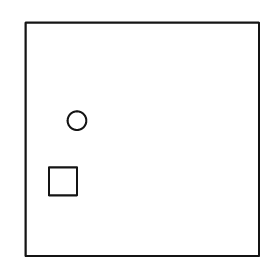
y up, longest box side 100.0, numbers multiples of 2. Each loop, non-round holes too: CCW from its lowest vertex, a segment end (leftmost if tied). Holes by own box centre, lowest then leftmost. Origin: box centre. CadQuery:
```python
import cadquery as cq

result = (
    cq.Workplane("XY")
    .moveTo(-50.0, -50.0)
    .lineTo(50.0, -50.0)
    .lineTo(50.0, 50.0)
    .lineTo(-50.0, 50.0)
    .close()
    .moveTo(-40.0, -24.0)
    .lineTo(-28.0, -24.0)
    .lineTo(-28.0, -12.0)
    .lineTo(-40.0, -12.0)
    .close()
    .moveTo(-28.0, 8.0)
    .circle(4.0)
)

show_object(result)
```